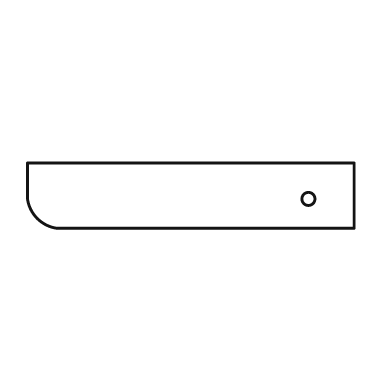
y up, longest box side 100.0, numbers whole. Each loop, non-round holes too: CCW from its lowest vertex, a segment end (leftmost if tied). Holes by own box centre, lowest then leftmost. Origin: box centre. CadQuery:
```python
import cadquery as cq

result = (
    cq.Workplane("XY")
    .moveTo(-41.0, -10.0)
    .lineTo(50.0, -10.0)
    .lineTo(50.0, 10.0)
    .lineTo(-50.0, 10.0)
    .lineTo(-50.0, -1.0)
    .threePointArc((-47.0, -7.0), (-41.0, -10.0))
    .close()
    .moveTo(36.0, -1.0)
    .circle(2.0)
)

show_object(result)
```